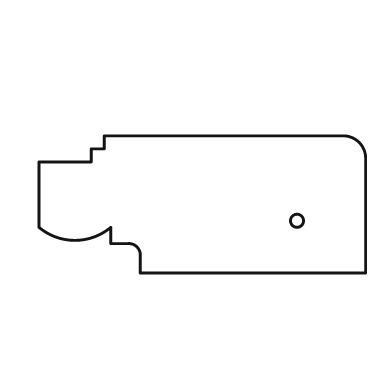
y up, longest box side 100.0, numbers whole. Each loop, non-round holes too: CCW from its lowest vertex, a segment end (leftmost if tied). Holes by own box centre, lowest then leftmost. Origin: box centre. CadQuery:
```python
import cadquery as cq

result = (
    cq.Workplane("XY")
    .moveTo(-19.0, -21.0)
    .lineTo(50.0, -21.0)
    .lineTo(50.0, 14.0)
    .threePointArc((48.0, 19.0), (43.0, 21.0))
    .lineTo(-30.0, 21.0)
    .lineTo(-30.0, 17.0)
    .lineTo(-34.0, 17.0)
    .lineTo(-34.0, 13.0)
    .lineTo(-50.0, 13.0)
    .lineTo(-50.0, -7.0)
    .threePointArc((-39.0, -11.0), (-28.0, -7.0))
    .lineTo(-28.0, -12.0)
    .lineTo(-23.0, -12.0)
    .threePointArc((-20.0, -13.0), (-19.0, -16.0))
    .close()
    .moveTo(29.0, -5.0)
    .circle(2.0)
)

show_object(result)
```